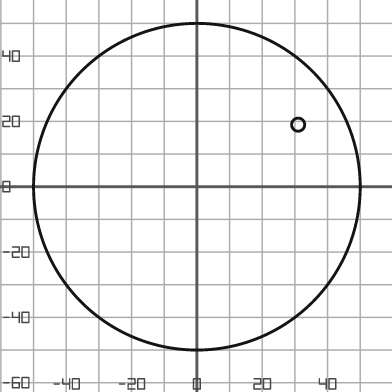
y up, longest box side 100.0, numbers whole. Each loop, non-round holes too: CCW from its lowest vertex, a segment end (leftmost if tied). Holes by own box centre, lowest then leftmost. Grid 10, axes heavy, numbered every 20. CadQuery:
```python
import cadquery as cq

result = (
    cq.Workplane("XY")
    .moveTo(0.0, 0.0)
    .circle(50.0)
    .moveTo(31.0, 19.0)
    .circle(2.0)
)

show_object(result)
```